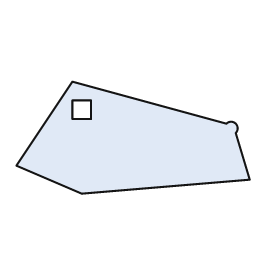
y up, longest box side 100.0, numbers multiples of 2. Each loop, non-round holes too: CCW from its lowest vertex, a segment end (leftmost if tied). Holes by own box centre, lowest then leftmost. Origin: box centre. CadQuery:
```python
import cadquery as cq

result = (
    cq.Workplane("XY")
    .moveTo(-22.0, -24.0)
    .lineTo(50.0, -18.0)
    .lineTo(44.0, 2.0)
    .threePointArc((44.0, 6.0), (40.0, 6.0))
    .lineTo(-26.0, 24.0)
    .lineTo(-50.0, -12.0)
    .close()
    .moveTo(-26.0, 8.0)
    .lineTo(-18.0, 8.0)
    .lineTo(-18.0, 16.0)
    .lineTo(-26.0, 16.0)
    .close()
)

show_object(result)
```